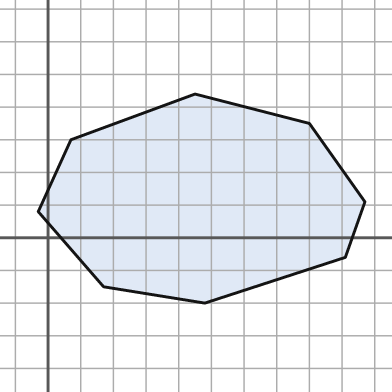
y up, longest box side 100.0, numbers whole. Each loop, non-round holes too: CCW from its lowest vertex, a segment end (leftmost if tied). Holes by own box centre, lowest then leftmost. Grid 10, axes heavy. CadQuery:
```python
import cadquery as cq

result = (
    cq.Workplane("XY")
    .moveTo(48.0, -20.0)
    .lineTo(91.0, -6.0)
    .lineTo(97.0, 11.0)
    .lineTo(80.0, 35.0)
    .lineTo(45.0, 44.0)
    .lineTo(7.0, 30.0)
    .lineTo(-3.0, 8.0)
    .lineTo(17.0, -15.0)
    .close()
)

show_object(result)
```